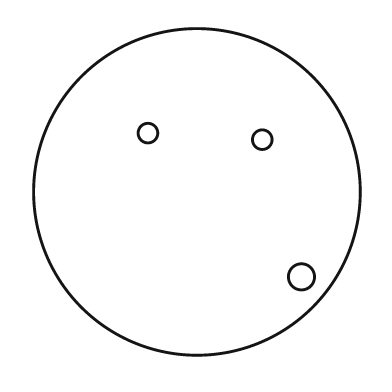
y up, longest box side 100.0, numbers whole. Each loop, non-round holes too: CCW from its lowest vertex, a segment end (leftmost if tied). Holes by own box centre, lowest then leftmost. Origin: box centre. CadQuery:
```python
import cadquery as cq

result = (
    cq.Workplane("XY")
    .moveTo(0.0, 0.0)
    .circle(50.0)
    .moveTo(32.0, -26.0)
    .circle(4.0)
    .moveTo(20.0, 16.0)
    .circle(3.0)
    .moveTo(-15.0, 18.0)
    .circle(3.0)
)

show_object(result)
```